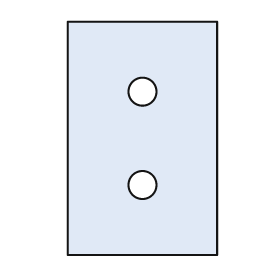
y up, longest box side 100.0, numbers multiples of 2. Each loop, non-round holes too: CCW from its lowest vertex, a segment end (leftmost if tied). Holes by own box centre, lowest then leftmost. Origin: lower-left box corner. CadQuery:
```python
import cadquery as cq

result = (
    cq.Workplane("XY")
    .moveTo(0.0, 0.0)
    .lineTo(64.0, 0.0)
    .lineTo(64.0, 100.0)
    .lineTo(0.0, 100.0)
    .close()
    .moveTo(32.0, 30.0)
    .circle(6.0)
    .moveTo(32.0, 70.0)
    .circle(6.0)
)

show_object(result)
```